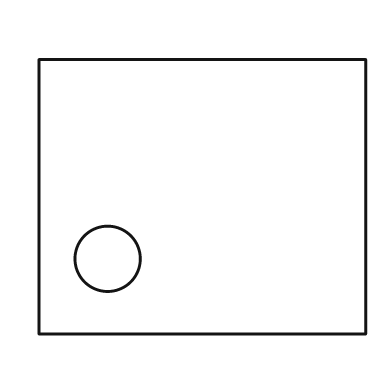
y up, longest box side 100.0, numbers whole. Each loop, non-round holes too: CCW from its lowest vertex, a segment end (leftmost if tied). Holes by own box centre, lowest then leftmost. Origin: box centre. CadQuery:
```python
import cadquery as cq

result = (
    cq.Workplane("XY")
    .moveTo(-50.0, -42.0)
    .lineTo(50.0, -42.0)
    .lineTo(50.0, 42.0)
    .lineTo(-50.0, 42.0)
    .close()
    .moveTo(-29.0, -19.0)
    .circle(10.0)
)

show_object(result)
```